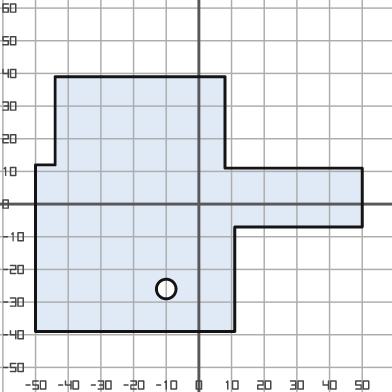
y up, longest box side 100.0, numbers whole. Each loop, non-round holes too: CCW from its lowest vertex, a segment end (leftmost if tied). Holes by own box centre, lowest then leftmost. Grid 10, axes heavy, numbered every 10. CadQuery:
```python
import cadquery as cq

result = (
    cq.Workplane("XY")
    .moveTo(-50.0, -39.0)
    .lineTo(11.0, -39.0)
    .lineTo(11.0, -7.0)
    .lineTo(50.0, -7.0)
    .lineTo(50.0, 11.0)
    .lineTo(8.0, 11.0)
    .lineTo(8.0, 39.0)
    .lineTo(-44.0, 39.0)
    .lineTo(-44.0, 12.0)
    .lineTo(-50.0, 12.0)
    .close()
    .moveTo(-10.0, -26.0)
    .circle(3.0)
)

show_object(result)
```